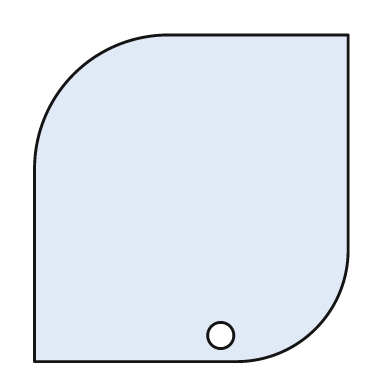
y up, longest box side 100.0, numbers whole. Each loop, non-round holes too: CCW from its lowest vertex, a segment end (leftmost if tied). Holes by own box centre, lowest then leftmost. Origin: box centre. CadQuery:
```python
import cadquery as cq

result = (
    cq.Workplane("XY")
    .moveTo(-48.0, -50.0)
    .lineTo(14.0, -50.0)
    .threePointArc((38.0, -40.0), (48.0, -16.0))
    .lineTo(48.0, 50.0)
    .lineTo(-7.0, 50.0)
    .threePointArc((-36.0, 38.0), (-48.0, 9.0))
    .close()
    .moveTo(9.0, -42.0)
    .circle(4.0)
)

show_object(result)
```